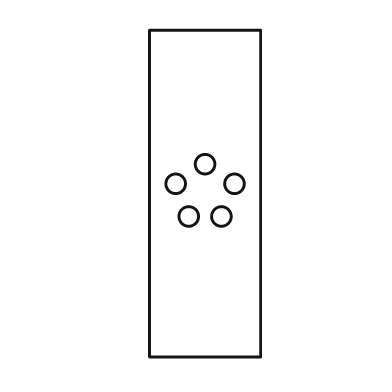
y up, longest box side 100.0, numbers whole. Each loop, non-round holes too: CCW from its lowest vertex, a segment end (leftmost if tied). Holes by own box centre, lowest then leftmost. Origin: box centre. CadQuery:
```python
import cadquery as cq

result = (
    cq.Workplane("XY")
    .moveTo(-17.0, -50.0)
    .lineTo(17.0, -50.0)
    .lineTo(17.0, 50.0)
    .lineTo(-17.0, 50.0)
    .close()
    .moveTo(-5.0, -7.0)
    .circle(3.0)
    .moveTo(5.0, -7.0)
    .circle(3.0)
    .moveTo(-9.0, 3.0)
    .circle(3.0)
    .moveTo(9.0, 3.0)
    .circle(3.0)
    .moveTo(0.0, 9.0)
    .circle(3.0)
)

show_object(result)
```